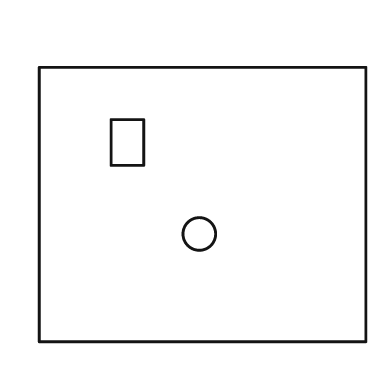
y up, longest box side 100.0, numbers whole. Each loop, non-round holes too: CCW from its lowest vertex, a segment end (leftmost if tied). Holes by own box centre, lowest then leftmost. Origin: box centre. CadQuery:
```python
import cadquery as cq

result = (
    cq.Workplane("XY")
    .moveTo(-50.0, -42.0)
    .lineTo(50.0, -42.0)
    .lineTo(50.0, 42.0)
    .lineTo(-50.0, 42.0)
    .close()
    .moveTo(-1.0, -9.0)
    .circle(5.0)
    .moveTo(-28.0, 12.0)
    .lineTo(-18.0, 12.0)
    .lineTo(-18.0, 26.0)
    .lineTo(-28.0, 26.0)
    .close()
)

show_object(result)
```